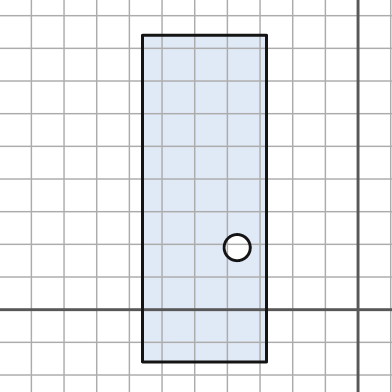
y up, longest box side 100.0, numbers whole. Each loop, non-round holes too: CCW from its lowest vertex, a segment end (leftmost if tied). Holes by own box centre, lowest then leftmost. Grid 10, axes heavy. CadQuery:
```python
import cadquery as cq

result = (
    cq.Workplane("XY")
    .moveTo(-66.0, -16.0)
    .lineTo(-28.0, -16.0)
    .lineTo(-28.0, 84.0)
    .lineTo(-66.0, 84.0)
    .close()
    .moveTo(-37.0, 19.0)
    .circle(4.0)
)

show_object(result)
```